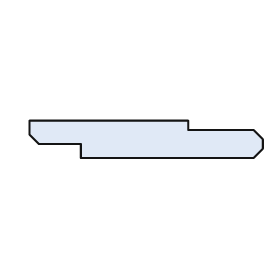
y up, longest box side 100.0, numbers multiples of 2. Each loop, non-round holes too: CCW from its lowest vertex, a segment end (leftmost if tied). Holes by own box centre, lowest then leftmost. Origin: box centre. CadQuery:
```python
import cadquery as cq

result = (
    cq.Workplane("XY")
    .moveTo(-28.0, -8.0)
    .lineTo(46.0, -8.0)
    .lineTo(50.0, -4.0)
    .lineTo(50.0, 0.0)
    .lineTo(46.0, 4.0)
    .lineTo(18.0, 4.0)
    .lineTo(18.0, 8.0)
    .lineTo(-50.0, 8.0)
    .lineTo(-50.0, 2.0)
    .lineTo(-46.0, -2.0)
    .lineTo(-28.0, -2.0)
    .close()
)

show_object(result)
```